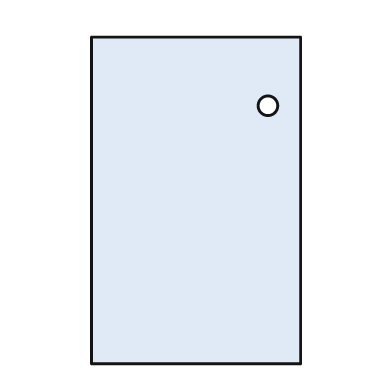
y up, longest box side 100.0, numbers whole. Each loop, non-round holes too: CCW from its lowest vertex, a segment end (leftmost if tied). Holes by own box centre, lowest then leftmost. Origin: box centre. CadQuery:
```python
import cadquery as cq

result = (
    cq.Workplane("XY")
    .moveTo(-32.0, -50.0)
    .lineTo(32.0, -50.0)
    .lineTo(32.0, 50.0)
    .lineTo(-32.0, 50.0)
    .close()
    .moveTo(22.0, 29.0)
    .circle(3.0)
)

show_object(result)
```